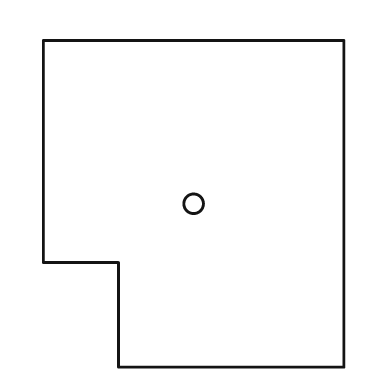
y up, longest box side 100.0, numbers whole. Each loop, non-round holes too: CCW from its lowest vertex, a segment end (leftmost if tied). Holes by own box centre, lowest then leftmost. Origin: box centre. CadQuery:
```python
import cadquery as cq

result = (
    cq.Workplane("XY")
    .moveTo(-23.0, -50.0)
    .lineTo(46.0, -50.0)
    .lineTo(46.0, 50.0)
    .lineTo(-46.0, 50.0)
    .lineTo(-46.0, -18.0)
    .lineTo(-23.0, -18.0)
    .close()
    .moveTo(0.0, 0.0)
    .circle(3.0)
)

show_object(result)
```